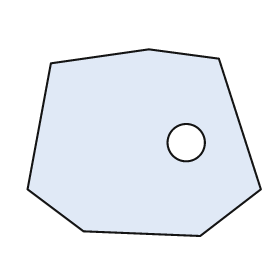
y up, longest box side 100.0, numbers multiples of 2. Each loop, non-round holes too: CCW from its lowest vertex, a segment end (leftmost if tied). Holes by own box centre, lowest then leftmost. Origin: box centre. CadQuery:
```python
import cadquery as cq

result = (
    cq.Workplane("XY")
    .moveTo(24.0, -40.0)
    .lineTo(50.0, -20.0)
    .lineTo(32.0, 36.0)
    .lineTo(2.0, 40.0)
    .lineTo(-40.0, 34.0)
    .lineTo(-50.0, -20.0)
    .lineTo(-26.0, -38.0)
    .close()
    .moveTo(18.0, 0.0)
    .circle(8.0)
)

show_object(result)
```